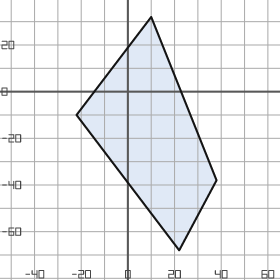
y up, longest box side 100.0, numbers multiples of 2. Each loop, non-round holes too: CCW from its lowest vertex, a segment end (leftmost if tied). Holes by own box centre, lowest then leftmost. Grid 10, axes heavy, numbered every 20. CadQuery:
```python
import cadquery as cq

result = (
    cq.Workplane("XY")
    .moveTo(22.0, -68.0)
    .lineTo(38.0, -38.0)
    .lineTo(10.0, 32.0)
    .lineTo(-22.0, -10.0)
    .close()
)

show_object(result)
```